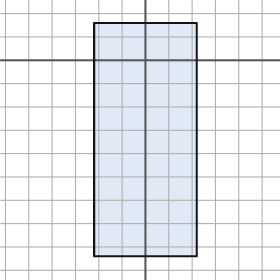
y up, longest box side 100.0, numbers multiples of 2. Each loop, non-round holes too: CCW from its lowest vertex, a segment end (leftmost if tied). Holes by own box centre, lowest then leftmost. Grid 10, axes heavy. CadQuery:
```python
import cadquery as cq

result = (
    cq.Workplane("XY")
    .moveTo(-22.0, -84.0)
    .lineTo(22.0, -84.0)
    .lineTo(22.0, 16.0)
    .lineTo(-22.0, 16.0)
    .close()
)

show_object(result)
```